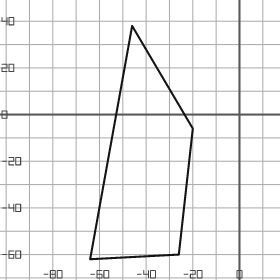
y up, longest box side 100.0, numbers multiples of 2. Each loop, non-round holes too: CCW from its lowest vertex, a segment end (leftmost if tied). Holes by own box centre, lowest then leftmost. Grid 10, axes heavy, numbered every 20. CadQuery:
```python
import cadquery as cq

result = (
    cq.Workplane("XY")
    .moveTo(-64.0, -62.0)
    .lineTo(-26.0, -60.0)
    .lineTo(-20.0, -6.0)
    .lineTo(-46.0, 38.0)
    .close()
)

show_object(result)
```